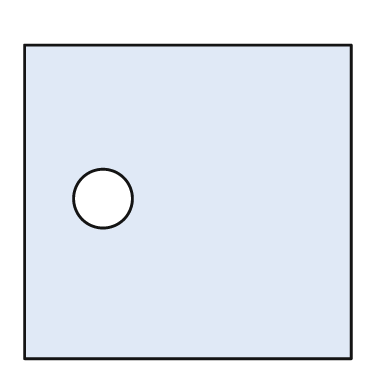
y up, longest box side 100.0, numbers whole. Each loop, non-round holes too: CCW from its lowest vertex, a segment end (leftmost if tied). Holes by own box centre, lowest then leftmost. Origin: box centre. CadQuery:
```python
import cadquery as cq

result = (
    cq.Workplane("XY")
    .moveTo(-50.0, -48.0)
    .lineTo(50.0, -48.0)
    .lineTo(50.0, 48.0)
    .lineTo(-50.0, 48.0)
    .close()
    .moveTo(-26.0, 1.0)
    .circle(9.0)
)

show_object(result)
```